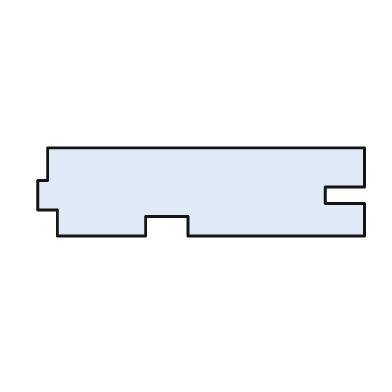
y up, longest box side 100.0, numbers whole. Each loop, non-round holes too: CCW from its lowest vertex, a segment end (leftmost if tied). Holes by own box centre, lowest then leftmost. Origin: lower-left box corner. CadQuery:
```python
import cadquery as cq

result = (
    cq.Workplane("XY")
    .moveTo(6.0, 0.0)
    .lineTo(33.0, 0.0)
    .lineTo(33.0, 6.0)
    .lineTo(46.0, 6.0)
    .lineTo(46.0, 0.0)
    .lineTo(100.0, 0.0)
    .lineTo(100.0, 10.0)
    .lineTo(88.0, 10.0)
    .lineTo(88.0, 15.0)
    .lineTo(100.0, 15.0)
    .lineTo(100.0, 27.0)
    .lineTo(3.0, 27.0)
    .lineTo(3.0, 17.0)
    .lineTo(0.0, 17.0)
    .lineTo(0.0, 8.0)
    .lineTo(6.0, 8.0)
    .close()
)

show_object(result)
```